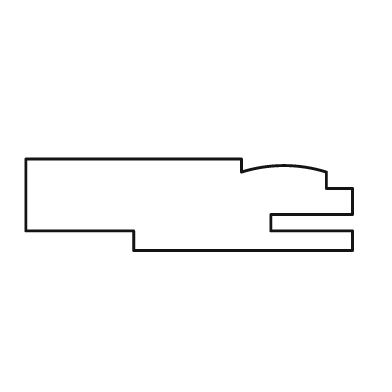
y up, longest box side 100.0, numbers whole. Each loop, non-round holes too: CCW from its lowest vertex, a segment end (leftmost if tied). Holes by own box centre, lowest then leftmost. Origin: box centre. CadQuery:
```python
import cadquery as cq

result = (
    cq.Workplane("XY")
    .moveTo(-17.0, -14.0)
    .lineTo(50.0, -14.0)
    .lineTo(50.0, -8.0)
    .lineTo(25.0, -8.0)
    .lineTo(25.0, -3.0)
    .lineTo(50.0, -3.0)
    .lineTo(50.0, 5.0)
    .lineTo(42.0, 5.0)
    .lineTo(42.0, 10.0)
    .threePointArc((29.0, 12.0), (16.0, 10.0))
    .lineTo(16.0, 14.0)
    .lineTo(-50.0, 14.0)
    .lineTo(-50.0, -8.0)
    .lineTo(-17.0, -8.0)
    .close()
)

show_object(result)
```